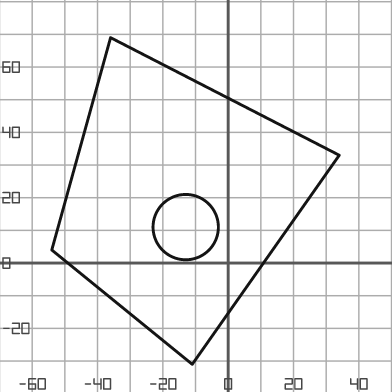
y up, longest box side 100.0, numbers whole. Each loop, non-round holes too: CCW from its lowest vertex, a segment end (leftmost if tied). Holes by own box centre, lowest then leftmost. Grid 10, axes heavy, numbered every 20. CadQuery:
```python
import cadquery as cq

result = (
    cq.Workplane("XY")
    .moveTo(-11.0, -31.0)
    .lineTo(34.0, 33.0)
    .lineTo(-36.0, 69.0)
    .lineTo(-54.0, 4.0)
    .close()
    .moveTo(-13.0, 11.0)
    .circle(10.0)
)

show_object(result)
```